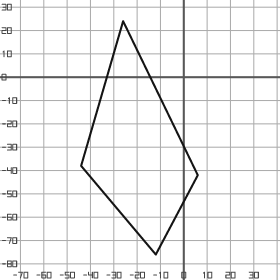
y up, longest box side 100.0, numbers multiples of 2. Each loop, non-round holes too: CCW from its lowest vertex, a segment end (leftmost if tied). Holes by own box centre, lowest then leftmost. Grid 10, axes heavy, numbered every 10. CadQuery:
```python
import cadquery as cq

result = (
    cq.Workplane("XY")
    .moveTo(-12.0, -76.0)
    .lineTo(6.0, -42.0)
    .lineTo(-26.0, 24.0)
    .lineTo(-44.0, -38.0)
    .close()
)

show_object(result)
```